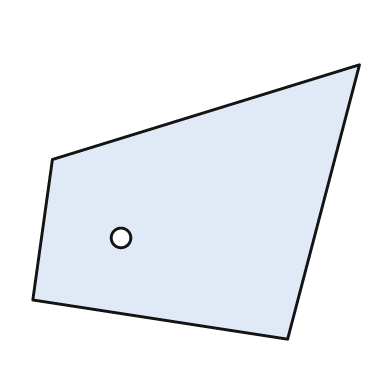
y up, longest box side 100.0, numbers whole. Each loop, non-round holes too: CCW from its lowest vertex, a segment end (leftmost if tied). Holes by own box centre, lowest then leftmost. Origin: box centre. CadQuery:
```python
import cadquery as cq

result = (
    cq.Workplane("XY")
    .moveTo(28.0, -42.0)
    .lineTo(50.0, 42.0)
    .lineTo(-44.0, 13.0)
    .lineTo(-50.0, -30.0)
    .close()
    .moveTo(-23.0, -11.0)
    .circle(3.0)
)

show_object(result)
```